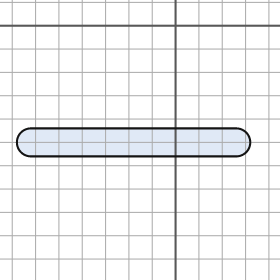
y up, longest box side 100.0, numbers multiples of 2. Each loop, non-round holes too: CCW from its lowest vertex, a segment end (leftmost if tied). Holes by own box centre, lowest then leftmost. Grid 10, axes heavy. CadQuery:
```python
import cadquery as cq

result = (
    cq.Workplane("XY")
    .moveTo(-62.0, -56.0)
    .lineTo(26.0, -56.0)
    .threePointArc((32.0, -50.0), (26.0, -44.0))
    .lineTo(-62.0, -44.0)
    .threePointArc((-68.0, -50.0), (-62.0, -56.0))
    .close()
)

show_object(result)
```